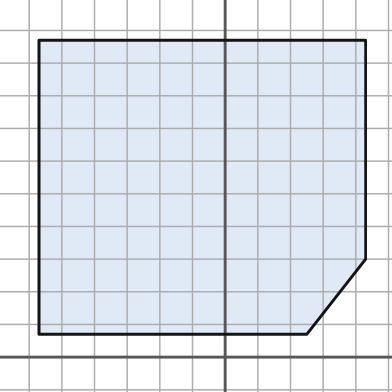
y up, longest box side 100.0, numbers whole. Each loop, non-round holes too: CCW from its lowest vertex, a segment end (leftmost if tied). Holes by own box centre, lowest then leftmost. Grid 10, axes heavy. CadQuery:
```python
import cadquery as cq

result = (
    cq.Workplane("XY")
    .moveTo(-57.0, 7.0)
    .lineTo(25.0, 7.0)
    .lineTo(43.0, 30.0)
    .lineTo(43.0, 97.0)
    .lineTo(-57.0, 97.0)
    .close()
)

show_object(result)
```